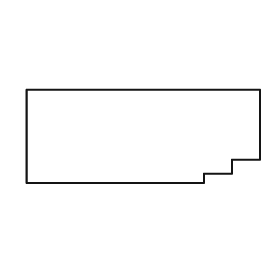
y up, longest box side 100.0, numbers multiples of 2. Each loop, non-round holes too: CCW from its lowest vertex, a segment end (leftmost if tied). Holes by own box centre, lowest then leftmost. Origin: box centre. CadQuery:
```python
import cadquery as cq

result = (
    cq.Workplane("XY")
    .moveTo(-50.0, -20.0)
    .lineTo(26.0, -20.0)
    .lineTo(26.0, -16.0)
    .lineTo(38.0, -16.0)
    .lineTo(38.0, -10.0)
    .lineTo(50.0, -10.0)
    .lineTo(50.0, 20.0)
    .lineTo(-50.0, 20.0)
    .close()
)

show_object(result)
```